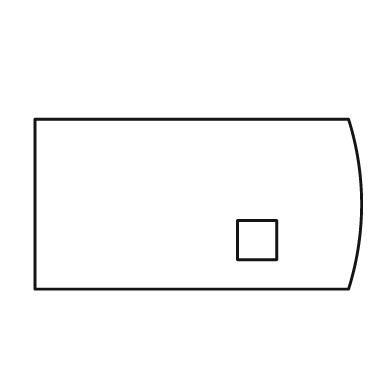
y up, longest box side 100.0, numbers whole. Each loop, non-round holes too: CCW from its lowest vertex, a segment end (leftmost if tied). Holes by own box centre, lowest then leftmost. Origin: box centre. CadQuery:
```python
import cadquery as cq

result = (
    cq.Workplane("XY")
    .moveTo(-50.0, -26.0)
    .lineTo(46.0, -26.0)
    .threePointArc((50.0, 0.0), (46.0, 26.0))
    .lineTo(-50.0, 26.0)
    .close()
    .moveTo(12.0, -17.0)
    .lineTo(24.0, -17.0)
    .lineTo(24.0, -5.0)
    .lineTo(12.0, -5.0)
    .close()
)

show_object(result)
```